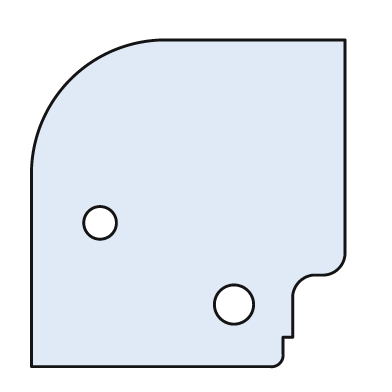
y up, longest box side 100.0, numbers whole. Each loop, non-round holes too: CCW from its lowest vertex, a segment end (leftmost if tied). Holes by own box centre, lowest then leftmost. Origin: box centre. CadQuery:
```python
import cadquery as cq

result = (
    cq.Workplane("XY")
    .moveTo(-48.0, -50.0)
    .lineTo(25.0, -50.0)
    .threePointArc((28.0, -49.0), (29.0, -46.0))
    .lineTo(29.0, -41.0)
    .lineTo(32.0, -41.0)
    .lineTo(32.0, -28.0)
    .threePointArc((34.0, -24.0), (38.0, -22.0))
    .lineTo(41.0, -22.0)
    .threePointArc((46.0, -20.0), (48.0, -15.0))
    .lineTo(48.0, 50.0)
    .lineTo(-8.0, 50.0)
    .threePointArc((-36.0, 38.0), (-48.0, 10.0))
    .close()
    .moveTo(14.0, -31.0)
    .circle(6.0)
    .moveTo(-27.0, -6.0)
    .circle(5.0)
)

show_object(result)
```